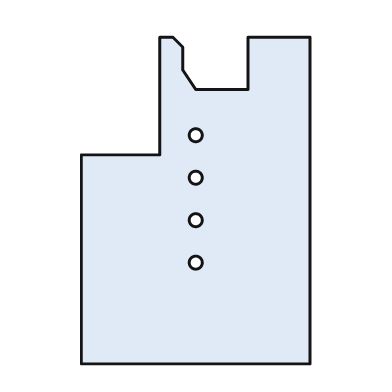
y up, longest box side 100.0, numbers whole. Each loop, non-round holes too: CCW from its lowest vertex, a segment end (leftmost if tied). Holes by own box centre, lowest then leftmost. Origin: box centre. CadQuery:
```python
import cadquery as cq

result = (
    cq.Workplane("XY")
    .moveTo(-35.0, -50.0)
    .lineTo(35.0, -50.0)
    .lineTo(35.0, 50.0)
    .lineTo(16.0, 50.0)
    .lineTo(16.0, 34.0)
    .lineTo(0.0, 34.0)
    .lineTo(-4.0, 40.0)
    .lineTo(-4.0, 47.0)
    .lineTo(-7.0, 50.0)
    .lineTo(-11.0, 50.0)
    .lineTo(-11.0, 14.0)
    .lineTo(-35.0, 14.0)
    .close()
    .moveTo(0.0, -19.0)
    .circle(2.0)
    .moveTo(0.0, -6.0)
    .circle(2.0)
    .moveTo(0.0, 7.0)
    .circle(2.0)
    .moveTo(0.0, 20.0)
    .circle(2.0)
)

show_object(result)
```